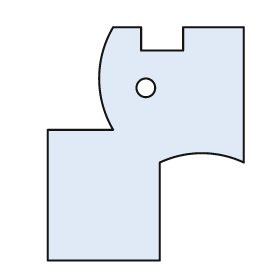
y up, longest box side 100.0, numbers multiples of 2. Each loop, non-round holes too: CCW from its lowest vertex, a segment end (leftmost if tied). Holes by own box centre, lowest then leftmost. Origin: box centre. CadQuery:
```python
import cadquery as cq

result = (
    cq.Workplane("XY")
    .moveTo(-42.0, -50.0)
    .lineTo(6.0, -50.0)
    .lineTo(6.0, -8.0)
    .threePointArc((24.0, -4.0), (42.0, -8.0))
    .lineTo(42.0, 50.0)
    .lineTo(16.0, 50.0)
    .lineTo(16.0, 40.0)
    .lineTo(-2.0, 40.0)
    .lineTo(-2.0, 50.0)
    .lineTo(-14.0, 50.0)
    .threePointArc((-20.0, 28.0), (-14.0, 6.0))
    .lineTo(-42.0, 6.0)
    .close()
    .moveTo(0.0, 24.0)
    .circle(4.0)
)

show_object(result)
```